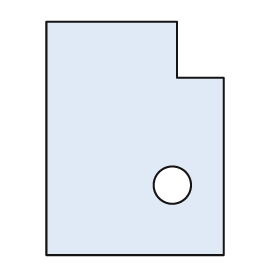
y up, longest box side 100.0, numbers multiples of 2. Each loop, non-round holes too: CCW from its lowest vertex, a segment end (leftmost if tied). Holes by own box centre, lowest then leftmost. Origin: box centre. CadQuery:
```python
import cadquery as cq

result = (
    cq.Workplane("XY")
    .moveTo(-38.0, -50.0)
    .lineTo(38.0, -50.0)
    .lineTo(38.0, 26.0)
    .lineTo(18.0, 26.0)
    .lineTo(18.0, 50.0)
    .lineTo(-38.0, 50.0)
    .close()
    .moveTo(16.0, -20.0)
    .circle(8.0)
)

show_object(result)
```